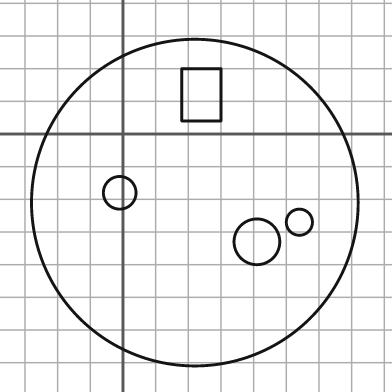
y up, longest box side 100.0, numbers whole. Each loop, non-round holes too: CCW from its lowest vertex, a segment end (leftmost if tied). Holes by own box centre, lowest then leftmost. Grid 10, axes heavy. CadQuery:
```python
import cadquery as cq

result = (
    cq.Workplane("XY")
    .moveTo(22.0, -21.0)
    .circle(50.0)
    .moveTo(41.0, -33.0)
    .circle(7.0)
    .moveTo(54.0, -27.0)
    .circle(4.0)
    .moveTo(-1.0, -18.0)
    .circle(5.0)
    .moveTo(18.0, 4.0)
    .lineTo(30.0, 4.0)
    .lineTo(30.0, 20.0)
    .lineTo(18.0, 20.0)
    .close()
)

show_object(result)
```